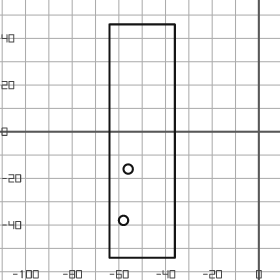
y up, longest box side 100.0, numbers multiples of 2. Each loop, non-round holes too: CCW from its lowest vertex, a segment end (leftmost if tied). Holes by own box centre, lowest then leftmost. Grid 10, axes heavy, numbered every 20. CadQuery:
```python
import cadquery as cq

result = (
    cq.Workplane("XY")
    .moveTo(-64.0, -54.0)
    .lineTo(-36.0, -54.0)
    .lineTo(-36.0, 46.0)
    .lineTo(-64.0, 46.0)
    .close()
    .moveTo(-58.0, -38.0)
    .circle(2.0)
    .moveTo(-56.0, -16.0)
    .circle(2.0)
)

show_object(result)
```